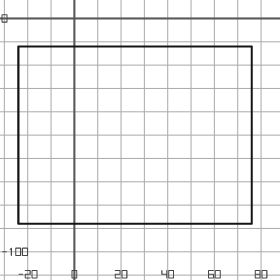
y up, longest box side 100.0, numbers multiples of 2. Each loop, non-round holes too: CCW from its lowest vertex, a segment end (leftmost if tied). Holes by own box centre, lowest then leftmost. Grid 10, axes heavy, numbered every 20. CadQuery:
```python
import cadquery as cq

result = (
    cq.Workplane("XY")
    .moveTo(-24.0, -88.0)
    .lineTo(76.0, -88.0)
    .lineTo(76.0, -12.0)
    .lineTo(-24.0, -12.0)
    .close()
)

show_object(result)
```